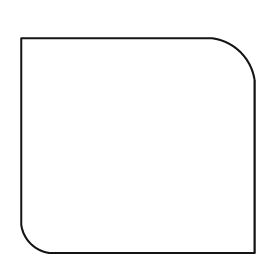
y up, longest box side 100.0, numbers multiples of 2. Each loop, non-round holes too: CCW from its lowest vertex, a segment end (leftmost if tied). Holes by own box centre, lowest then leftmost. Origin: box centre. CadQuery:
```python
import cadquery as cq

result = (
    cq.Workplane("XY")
    .moveTo(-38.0, -46.0)
    .lineTo(50.0, -46.0)
    .lineTo(50.0, 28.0)
    .threePointArc((44.0, 40.0), (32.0, 46.0))
    .lineTo(-50.0, 46.0)
    .lineTo(-50.0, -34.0)
    .threePointArc((-46.0, -42.0), (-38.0, -46.0))
    .close()
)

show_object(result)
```